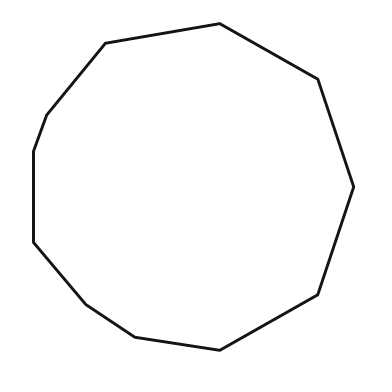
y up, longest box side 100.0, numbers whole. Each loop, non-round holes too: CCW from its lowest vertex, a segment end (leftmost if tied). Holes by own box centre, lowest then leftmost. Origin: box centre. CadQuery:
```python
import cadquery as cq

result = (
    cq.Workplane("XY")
    .moveTo(8.0, -50.0)
    .lineTo(38.0, -33.0)
    .lineTo(49.0, 0.0)
    .lineTo(38.0, 33.0)
    .lineTo(8.0, 50.0)
    .lineTo(-27.0, 44.0)
    .lineTo(-45.0, 22.0)
    .lineTo(-49.0, 11.0)
    .lineTo(-49.0, -17.0)
    .lineTo(-33.0, -36.0)
    .lineTo(-18.0, -46.0)
    .close()
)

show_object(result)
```